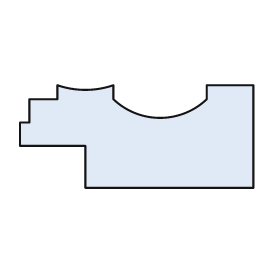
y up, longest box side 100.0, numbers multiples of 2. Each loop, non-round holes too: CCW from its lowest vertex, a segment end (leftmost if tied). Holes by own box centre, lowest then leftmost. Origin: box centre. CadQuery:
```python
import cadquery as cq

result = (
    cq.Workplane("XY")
    .moveTo(-22.0, -22.0)
    .lineTo(50.0, -22.0)
    .lineTo(50.0, 22.0)
    .lineTo(30.0, 22.0)
    .lineTo(30.0, 16.0)
    .threePointArc((10.0, 8.0), (-10.0, 16.0))
    .lineTo(-10.0, 22.0)
    .threePointArc((-22.0, 20.0), (-34.0, 22.0))
    .lineTo(-34.0, 16.0)
    .lineTo(-46.0, 16.0)
    .lineTo(-46.0, 6.0)
    .lineTo(-50.0, 6.0)
    .lineTo(-50.0, -4.0)
    .lineTo(-22.0, -4.0)
    .close()
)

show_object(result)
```